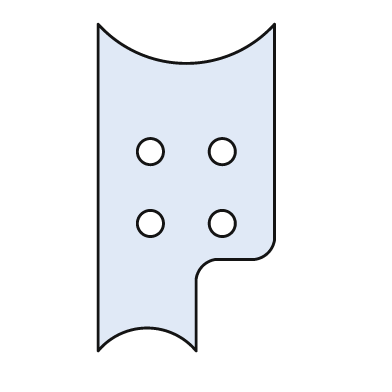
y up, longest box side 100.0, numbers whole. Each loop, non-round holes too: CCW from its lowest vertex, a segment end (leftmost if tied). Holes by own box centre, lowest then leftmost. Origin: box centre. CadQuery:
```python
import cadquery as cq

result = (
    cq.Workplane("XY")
    .moveTo(-27.0, -50.0)
    .threePointArc((-12.0, -43.0), (3.0, -50.0))
    .lineTo(3.0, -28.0)
    .threePointArc((5.0, -24.0), (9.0, -22.0))
    .lineTo(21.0, -22.0)
    .threePointArc((25.0, -20.0), (27.0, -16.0))
    .lineTo(27.0, 50.0)
    .threePointArc((0.0, 38.0), (-27.0, 50.0))
    .close()
    .moveTo(-11.0, -11.0)
    .circle(4.0)
    .moveTo(11.0, -11.0)
    .circle(4.0)
    .moveTo(-11.0, 11.0)
    .circle(4.0)
    .moveTo(11.0, 11.0)
    .circle(4.0)
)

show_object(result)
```